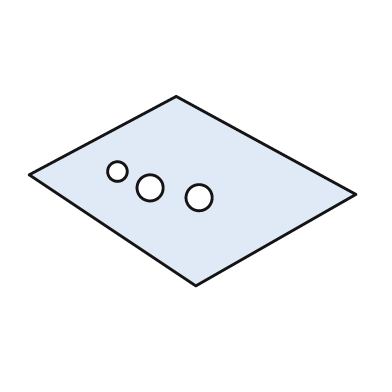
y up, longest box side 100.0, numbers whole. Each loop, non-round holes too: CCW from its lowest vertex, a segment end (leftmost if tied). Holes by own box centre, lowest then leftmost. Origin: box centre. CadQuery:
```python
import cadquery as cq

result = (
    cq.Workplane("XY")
    .moveTo(1.0, -29.0)
    .lineTo(50.0, -1.0)
    .lineTo(-5.0, 29.0)
    .lineTo(-50.0, 5.0)
    .close()
    .moveTo(2.0, -2.0)
    .circle(4.0)
    .moveTo(-13.0, 1.0)
    .circle(4.0)
    .moveTo(-23.0, 6.0)
    .circle(3.0)
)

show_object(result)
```